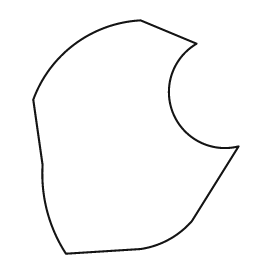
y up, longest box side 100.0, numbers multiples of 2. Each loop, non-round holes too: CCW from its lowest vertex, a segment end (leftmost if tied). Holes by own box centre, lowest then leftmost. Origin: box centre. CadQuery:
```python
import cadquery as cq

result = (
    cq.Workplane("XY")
    .moveTo(-30.0, -50.0)
    .lineTo(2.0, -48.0)
    .threePointArc((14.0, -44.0), (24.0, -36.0))
    .lineTo(44.0, -4.0)
    .threePointArc((16.0, 10.0), (26.0, 40.0))
    .lineTo(2.0, 50.0)
    .threePointArc((-26.0, 40.0), (-44.0, 16.0))
    .lineTo(-40.0, -12.0)
    .threePointArc((-38.0, -32.0), (-30.0, -50.0))
    .close()
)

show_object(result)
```